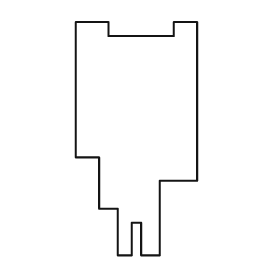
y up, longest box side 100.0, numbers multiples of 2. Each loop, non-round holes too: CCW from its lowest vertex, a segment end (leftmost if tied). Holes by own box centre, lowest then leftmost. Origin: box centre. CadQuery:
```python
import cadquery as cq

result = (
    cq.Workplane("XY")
    .moveTo(-8.0, -50.0)
    .lineTo(-2.0, -50.0)
    .lineTo(-2.0, -36.0)
    .lineTo(2.0, -36.0)
    .lineTo(2.0, -50.0)
    .lineTo(10.0, -50.0)
    .lineTo(10.0, -18.0)
    .lineTo(26.0, -18.0)
    .lineTo(26.0, 50.0)
    .lineTo(16.0, 50.0)
    .lineTo(16.0, 44.0)
    .lineTo(-12.0, 44.0)
    .lineTo(-12.0, 50.0)
    .lineTo(-26.0, 50.0)
    .lineTo(-26.0, -8.0)
    .lineTo(-16.0, -8.0)
    .lineTo(-16.0, -30.0)
    .lineTo(-8.0, -30.0)
    .close()
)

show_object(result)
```